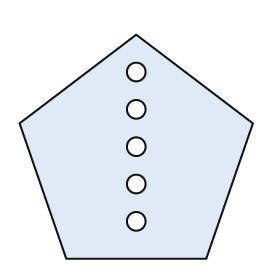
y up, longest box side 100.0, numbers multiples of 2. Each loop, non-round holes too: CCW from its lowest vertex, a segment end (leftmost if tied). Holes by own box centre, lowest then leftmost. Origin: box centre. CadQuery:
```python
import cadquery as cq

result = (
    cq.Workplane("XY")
    .moveTo(-30.0, -48.0)
    .lineTo(30.0, -48.0)
    .lineTo(50.0, 10.0)
    .lineTo(0.0, 48.0)
    .lineTo(-50.0, 10.0)
    .close()
    .moveTo(0.0, -32.0)
    .circle(4.0)
    .moveTo(0.0, -16.0)
    .circle(4.0)
    .moveTo(0.0, 0.0)
    .circle(4.0)
    .moveTo(0.0, 16.0)
    .circle(4.0)
    .moveTo(0.0, 32.0)
    .circle(4.0)
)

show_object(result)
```